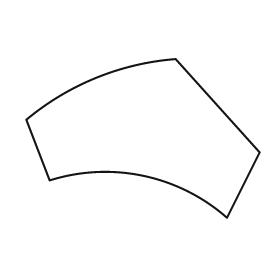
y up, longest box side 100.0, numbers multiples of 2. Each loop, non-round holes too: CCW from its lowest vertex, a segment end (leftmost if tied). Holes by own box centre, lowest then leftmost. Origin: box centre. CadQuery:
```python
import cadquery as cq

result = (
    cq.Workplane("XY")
    .moveTo(36.0, -34.0)
    .lineTo(50.0, -6.0)
    .lineTo(14.0, 34.0)
    .threePointArc((-20.0, 26.0), (-50.0, 8.0))
    .lineTo(-40.0, -18.0)
    .threePointArc((0.0, -16.0), (36.0, -34.0))
    .close()
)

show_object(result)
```